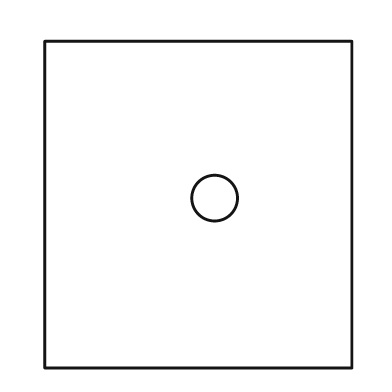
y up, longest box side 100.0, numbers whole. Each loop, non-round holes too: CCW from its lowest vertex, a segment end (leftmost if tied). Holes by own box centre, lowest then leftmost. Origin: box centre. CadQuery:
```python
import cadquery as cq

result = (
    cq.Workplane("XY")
    .moveTo(-47.0, -50.0)
    .lineTo(47.0, -50.0)
    .lineTo(47.0, 50.0)
    .lineTo(-47.0, 50.0)
    .close()
    .moveTo(5.0, 2.0)
    .circle(7.0)
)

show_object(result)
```